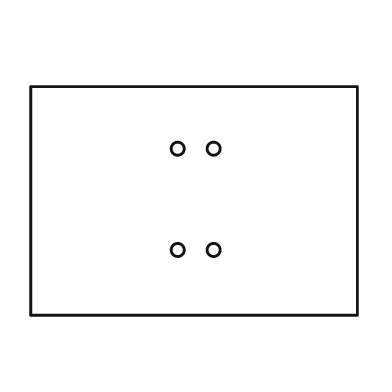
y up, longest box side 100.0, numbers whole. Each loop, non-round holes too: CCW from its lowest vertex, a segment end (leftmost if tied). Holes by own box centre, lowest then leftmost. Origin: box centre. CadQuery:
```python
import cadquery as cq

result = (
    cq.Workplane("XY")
    .moveTo(-50.0, -35.0)
    .lineTo(50.0, -35.0)
    .lineTo(50.0, 35.0)
    .lineTo(-50.0, 35.0)
    .close()
    .moveTo(-5.0, -15.0)
    .circle(2.0)
    .moveTo(6.0, -15.0)
    .circle(2.0)
    .moveTo(-5.0, 16.0)
    .circle(2.0)
    .moveTo(6.0, 16.0)
    .circle(2.0)
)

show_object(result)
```